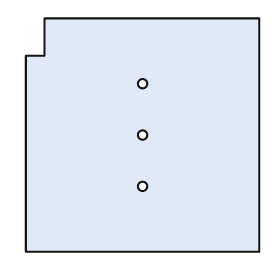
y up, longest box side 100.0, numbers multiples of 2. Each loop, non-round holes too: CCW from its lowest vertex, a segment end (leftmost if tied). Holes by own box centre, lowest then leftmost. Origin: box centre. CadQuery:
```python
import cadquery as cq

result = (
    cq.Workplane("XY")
    .moveTo(-50.0, -50.0)
    .lineTo(50.0, -50.0)
    .lineTo(50.0, 50.0)
    .lineTo(-42.0, 50.0)
    .lineTo(-42.0, 34.0)
    .lineTo(-50.0, 34.0)
    .close()
    .moveTo(0.0, -22.0)
    .circle(2.0)
    .moveTo(0.0, 0.0)
    .circle(2.0)
    .moveTo(0.0, 22.0)
    .circle(2.0)
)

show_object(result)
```